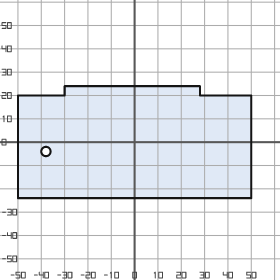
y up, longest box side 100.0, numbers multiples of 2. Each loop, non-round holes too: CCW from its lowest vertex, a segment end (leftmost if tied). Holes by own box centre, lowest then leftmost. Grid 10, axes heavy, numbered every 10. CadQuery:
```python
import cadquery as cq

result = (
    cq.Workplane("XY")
    .moveTo(-50.0, -24.0)
    .lineTo(50.0, -24.0)
    .lineTo(50.0, 20.0)
    .lineTo(28.0, 20.0)
    .lineTo(28.0, 24.0)
    .lineTo(-30.0, 24.0)
    .lineTo(-30.0, 20.0)
    .lineTo(-50.0, 20.0)
    .close()
    .moveTo(-38.0, -4.0)
    .circle(2.0)
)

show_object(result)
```